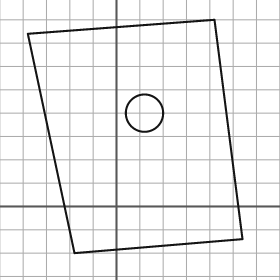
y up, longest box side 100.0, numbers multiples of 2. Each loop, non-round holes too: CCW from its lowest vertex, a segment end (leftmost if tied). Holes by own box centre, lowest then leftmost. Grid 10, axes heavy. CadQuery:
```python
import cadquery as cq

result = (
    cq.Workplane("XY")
    .moveTo(-18.0, -20.0)
    .lineTo(54.0, -14.0)
    .lineTo(42.0, 80.0)
    .lineTo(-38.0, 74.0)
    .close()
    .moveTo(12.0, 40.0)
    .circle(8.0)
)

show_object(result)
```